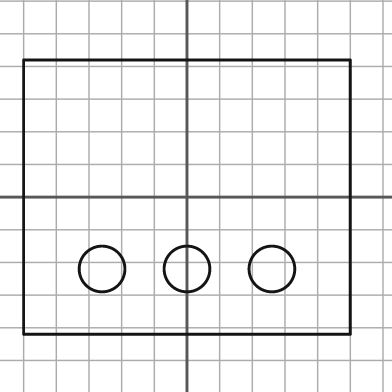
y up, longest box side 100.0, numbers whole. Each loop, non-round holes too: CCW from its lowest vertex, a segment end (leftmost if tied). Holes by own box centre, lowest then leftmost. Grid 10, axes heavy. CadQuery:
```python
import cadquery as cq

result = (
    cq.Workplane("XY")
    .moveTo(-50.0, -42.0)
    .lineTo(50.0, -42.0)
    .lineTo(50.0, 42.0)
    .lineTo(-50.0, 42.0)
    .close()
    .moveTo(-26.0, -22.0)
    .circle(7.0)
    .moveTo(0.0, -22.0)
    .circle(7.0)
    .moveTo(26.0, -22.0)
    .circle(7.0)
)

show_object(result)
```